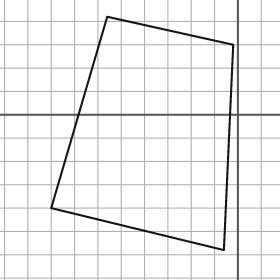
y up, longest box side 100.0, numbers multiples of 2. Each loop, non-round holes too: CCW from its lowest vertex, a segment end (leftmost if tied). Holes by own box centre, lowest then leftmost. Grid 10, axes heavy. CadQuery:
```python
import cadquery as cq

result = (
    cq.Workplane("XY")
    .moveTo(-6.0, -58.0)
    .lineTo(-2.0, 30.0)
    .lineTo(-56.0, 42.0)
    .lineTo(-80.0, -40.0)
    .close()
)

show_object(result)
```